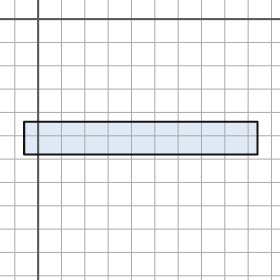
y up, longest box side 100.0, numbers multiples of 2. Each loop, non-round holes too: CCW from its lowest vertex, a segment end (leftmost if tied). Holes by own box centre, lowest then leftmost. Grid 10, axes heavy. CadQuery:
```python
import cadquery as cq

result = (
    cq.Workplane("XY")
    .moveTo(-6.0, -58.0)
    .lineTo(94.0, -58.0)
    .lineTo(94.0, -44.0)
    .lineTo(-6.0, -44.0)
    .close()
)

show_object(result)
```